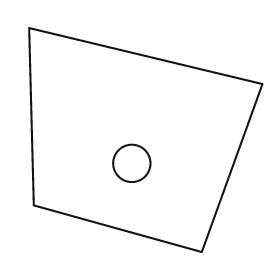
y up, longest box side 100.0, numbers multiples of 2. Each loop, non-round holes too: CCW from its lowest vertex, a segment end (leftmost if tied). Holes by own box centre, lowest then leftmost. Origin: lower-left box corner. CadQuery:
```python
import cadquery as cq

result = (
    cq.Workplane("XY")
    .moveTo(74.0, 0.0)
    .lineTo(100.0, 72.0)
    .lineTo(0.0, 96.0)
    .lineTo(2.0, 20.0)
    .close()
    .moveTo(44.0, 38.0)
    .circle(8.0)
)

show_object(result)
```